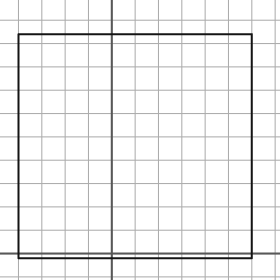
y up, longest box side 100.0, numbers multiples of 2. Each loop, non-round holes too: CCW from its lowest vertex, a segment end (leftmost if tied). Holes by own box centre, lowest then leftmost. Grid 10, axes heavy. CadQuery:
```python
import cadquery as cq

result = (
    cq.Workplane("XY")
    .moveTo(-40.0, -2.0)
    .lineTo(60.0, -2.0)
    .lineTo(60.0, 94.0)
    .lineTo(-40.0, 94.0)
    .close()
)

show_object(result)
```